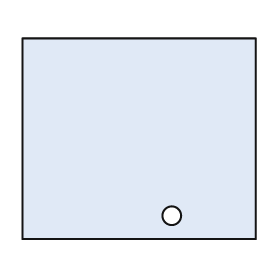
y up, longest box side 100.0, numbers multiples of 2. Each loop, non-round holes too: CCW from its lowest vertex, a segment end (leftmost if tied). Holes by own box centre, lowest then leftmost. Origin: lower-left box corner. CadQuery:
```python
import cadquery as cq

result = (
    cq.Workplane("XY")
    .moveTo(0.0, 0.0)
    .lineTo(100.0, 0.0)
    .lineTo(100.0, 86.0)
    .lineTo(0.0, 86.0)
    .close()
    .moveTo(64.0, 10.0)
    .circle(4.0)
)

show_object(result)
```